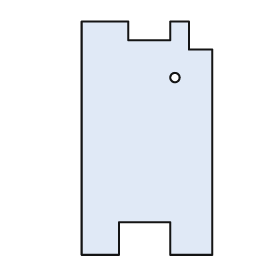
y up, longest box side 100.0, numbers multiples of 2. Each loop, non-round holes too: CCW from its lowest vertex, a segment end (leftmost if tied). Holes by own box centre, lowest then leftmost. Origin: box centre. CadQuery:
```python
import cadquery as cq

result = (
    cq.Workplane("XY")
    .moveTo(-28.0, -50.0)
    .lineTo(-12.0, -50.0)
    .lineTo(-12.0, -36.0)
    .lineTo(10.0, -36.0)
    .lineTo(10.0, -50.0)
    .lineTo(28.0, -50.0)
    .lineTo(28.0, 38.0)
    .lineTo(18.0, 38.0)
    .lineTo(18.0, 50.0)
    .lineTo(10.0, 50.0)
    .lineTo(10.0, 42.0)
    .lineTo(-8.0, 42.0)
    .lineTo(-8.0, 50.0)
    .lineTo(-28.0, 50.0)
    .close()
    .moveTo(12.0, 26.0)
    .circle(2.0)
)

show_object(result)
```